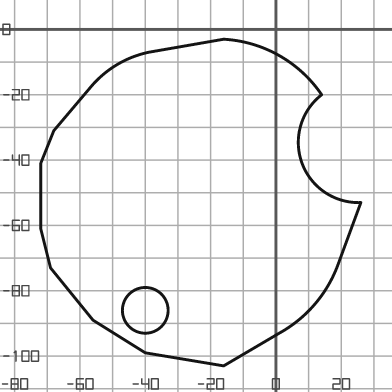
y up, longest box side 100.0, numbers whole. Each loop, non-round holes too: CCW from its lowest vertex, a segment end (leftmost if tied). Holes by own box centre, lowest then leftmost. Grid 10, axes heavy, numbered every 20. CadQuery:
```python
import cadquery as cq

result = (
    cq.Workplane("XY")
    .moveTo(-16.0, -103.0)
    .lineTo(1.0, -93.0)
    .threePointArc((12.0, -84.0), (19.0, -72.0))
    .lineTo(26.0, -53.0)
    .threePointArc((8.0, -41.0), (14.0, -20.0))
    .threePointArc((1.0, -8.0), (-16.0, -3.0))
    .lineTo(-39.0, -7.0)
    .threePointArc((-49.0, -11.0), (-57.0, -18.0))
    .lineTo(-68.0, -31.0)
    .lineTo(-72.0, -41.0)
    .lineTo(-72.0, -61.0)
    .lineTo(-69.0, -73.0)
    .lineTo(-56.0, -89.0)
    .lineTo(-40.0, -99.0)
    .close()
    .moveTo(-40.0, -86.0)
    .circle(7.0)
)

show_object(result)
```